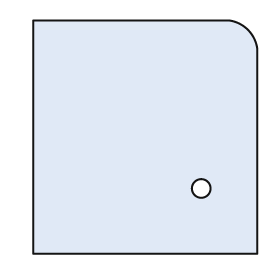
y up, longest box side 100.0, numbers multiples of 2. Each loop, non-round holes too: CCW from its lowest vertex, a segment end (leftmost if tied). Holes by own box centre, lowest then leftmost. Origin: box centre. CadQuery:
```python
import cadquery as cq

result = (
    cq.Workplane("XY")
    .moveTo(-48.0, -50.0)
    .lineTo(48.0, -50.0)
    .lineTo(48.0, 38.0)
    .threePointArc((44.0, 46.0), (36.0, 50.0))
    .lineTo(-48.0, 50.0)
    .close()
    .moveTo(24.0, -22.0)
    .circle(4.0)
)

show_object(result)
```